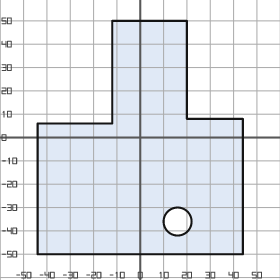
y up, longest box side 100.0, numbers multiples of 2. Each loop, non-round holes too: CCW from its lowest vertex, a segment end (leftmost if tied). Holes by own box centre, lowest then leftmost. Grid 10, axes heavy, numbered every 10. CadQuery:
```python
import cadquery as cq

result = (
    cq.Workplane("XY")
    .moveTo(-44.0, -50.0)
    .lineTo(44.0, -50.0)
    .lineTo(44.0, 8.0)
    .lineTo(20.0, 8.0)
    .lineTo(20.0, 50.0)
    .lineTo(-12.0, 50.0)
    .lineTo(-12.0, 6.0)
    .lineTo(-44.0, 6.0)
    .close()
    .moveTo(16.0, -36.0)
    .circle(6.0)
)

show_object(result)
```